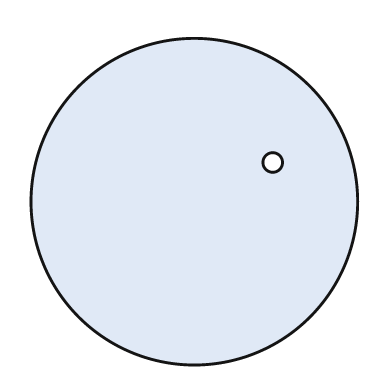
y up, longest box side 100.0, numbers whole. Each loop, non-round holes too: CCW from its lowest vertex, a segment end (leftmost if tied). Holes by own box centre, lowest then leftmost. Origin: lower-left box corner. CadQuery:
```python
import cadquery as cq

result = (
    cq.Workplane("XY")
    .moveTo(50.0, 50.0)
    .circle(50.0)
    .moveTo(74.0, 62.0)
    .circle(3.0)
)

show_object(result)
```